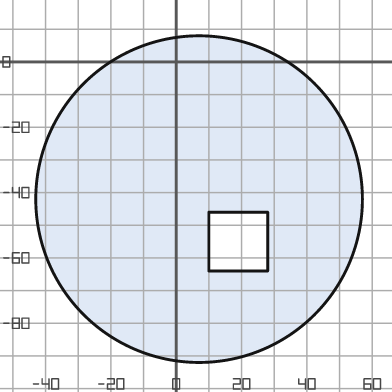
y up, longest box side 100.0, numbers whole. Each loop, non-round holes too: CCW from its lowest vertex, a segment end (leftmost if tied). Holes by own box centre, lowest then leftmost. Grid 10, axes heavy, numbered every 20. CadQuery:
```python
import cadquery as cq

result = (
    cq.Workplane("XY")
    .moveTo(7.0, -42.0)
    .circle(50.0)
    .moveTo(10.0, -64.0)
    .lineTo(28.0, -64.0)
    .lineTo(28.0, -46.0)
    .lineTo(10.0, -46.0)
    .close()
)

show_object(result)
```